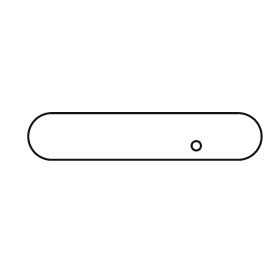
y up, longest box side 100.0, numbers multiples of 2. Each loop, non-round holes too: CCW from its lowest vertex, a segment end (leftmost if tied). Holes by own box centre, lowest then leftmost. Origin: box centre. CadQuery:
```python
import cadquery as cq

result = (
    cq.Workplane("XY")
    .moveTo(-40.0, -10.0)
    .lineTo(40.0, -10.0)
    .threePointArc((50.0, 0.0), (40.0, 10.0))
    .lineTo(-40.0, 10.0)
    .threePointArc((-50.0, 0.0), (-40.0, -10.0))
    .close()
    .moveTo(22.0, -4.0)
    .circle(2.0)
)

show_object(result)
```